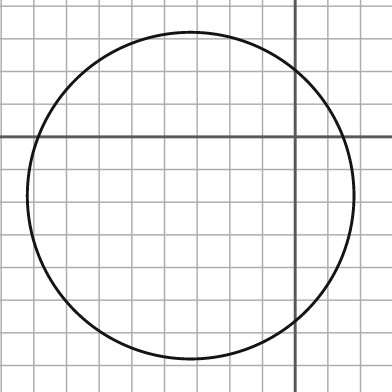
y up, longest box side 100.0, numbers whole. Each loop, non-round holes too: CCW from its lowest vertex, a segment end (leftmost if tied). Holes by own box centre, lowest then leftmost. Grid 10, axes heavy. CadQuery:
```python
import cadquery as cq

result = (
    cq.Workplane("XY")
    .moveTo(-32.0, -18.0)
    .circle(50.0)
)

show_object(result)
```